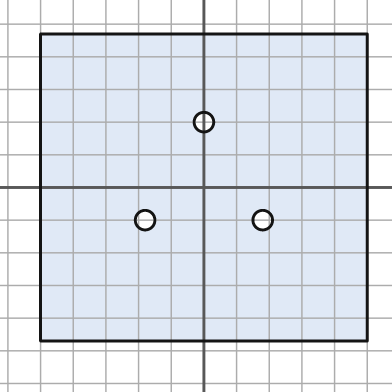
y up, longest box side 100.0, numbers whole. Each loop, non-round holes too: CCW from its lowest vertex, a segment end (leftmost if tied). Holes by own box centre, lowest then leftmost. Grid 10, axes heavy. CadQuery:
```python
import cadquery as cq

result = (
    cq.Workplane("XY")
    .moveTo(-50.0, -47.0)
    .lineTo(50.0, -47.0)
    .lineTo(50.0, 47.0)
    .lineTo(-50.0, 47.0)
    .close()
    .moveTo(-18.0, -10.0)
    .circle(3.0)
    .moveTo(18.0, -10.0)
    .circle(3.0)
    .moveTo(0.0, 20.0)
    .circle(3.0)
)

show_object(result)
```